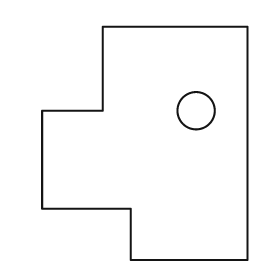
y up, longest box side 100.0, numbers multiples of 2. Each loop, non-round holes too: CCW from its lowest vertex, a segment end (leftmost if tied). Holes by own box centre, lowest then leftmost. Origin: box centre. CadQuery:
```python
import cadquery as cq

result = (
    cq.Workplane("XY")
    .moveTo(-6.0, -50.0)
    .lineTo(44.0, -50.0)
    .lineTo(44.0, 50.0)
    .lineTo(-18.0, 50.0)
    .lineTo(-18.0, 14.0)
    .lineTo(-44.0, 14.0)
    .lineTo(-44.0, -28.0)
    .lineTo(-6.0, -28.0)
    .close()
    .moveTo(22.0, 14.0)
    .circle(8.0)
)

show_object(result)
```